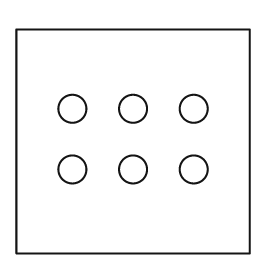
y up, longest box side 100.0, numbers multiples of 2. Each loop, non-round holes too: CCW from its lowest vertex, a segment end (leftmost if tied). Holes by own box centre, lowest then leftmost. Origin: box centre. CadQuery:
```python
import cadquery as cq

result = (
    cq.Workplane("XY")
    .moveTo(-50.0, -48.0)
    .lineTo(50.0, -48.0)
    .lineTo(50.0, 48.0)
    .lineTo(-50.0, 48.0)
    .close()
    .moveTo(-26.0, -12.0)
    .circle(6.0)
    .moveTo(0.0, -12.0)
    .circle(6.0)
    .moveTo(26.0, -12.0)
    .circle(6.0)
    .moveTo(-26.0, 14.0)
    .circle(6.0)
    .moveTo(0.0, 14.0)
    .circle(6.0)
    .moveTo(26.0, 14.0)
    .circle(6.0)
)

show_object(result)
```